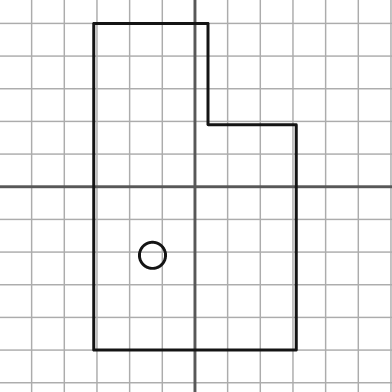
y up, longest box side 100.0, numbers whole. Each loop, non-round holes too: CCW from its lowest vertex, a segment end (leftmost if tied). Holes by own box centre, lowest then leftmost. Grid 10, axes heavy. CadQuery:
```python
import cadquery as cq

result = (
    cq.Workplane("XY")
    .moveTo(-31.0, -50.0)
    .lineTo(31.0, -50.0)
    .lineTo(31.0, 19.0)
    .lineTo(4.0, 19.0)
    .lineTo(4.0, 50.0)
    .lineTo(-31.0, 50.0)
    .close()
    .moveTo(-13.0, -21.0)
    .circle(4.0)
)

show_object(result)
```